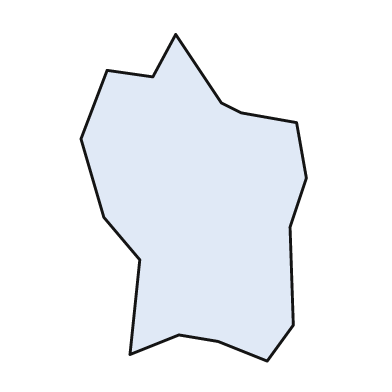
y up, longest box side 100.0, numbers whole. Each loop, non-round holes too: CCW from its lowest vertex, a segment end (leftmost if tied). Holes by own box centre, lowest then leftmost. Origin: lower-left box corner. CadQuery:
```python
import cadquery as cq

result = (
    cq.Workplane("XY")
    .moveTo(57.0, 0.0)
    .lineTo(65.0, 11.0)
    .lineTo(64.0, 41.0)
    .lineTo(69.0, 56.0)
    .lineTo(66.0, 73.0)
    .lineTo(49.0, 76.0)
    .lineTo(43.0, 79.0)
    .lineTo(29.0, 100.0)
    .lineTo(22.0, 87.0)
    .lineTo(8.0, 89.0)
    .lineTo(0.0, 68.0)
    .lineTo(7.0, 44.0)
    .lineTo(18.0, 31.0)
    .lineTo(15.0, 2.0)
    .lineTo(30.0, 8.0)
    .lineTo(42.0, 6.0)
    .close()
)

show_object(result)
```